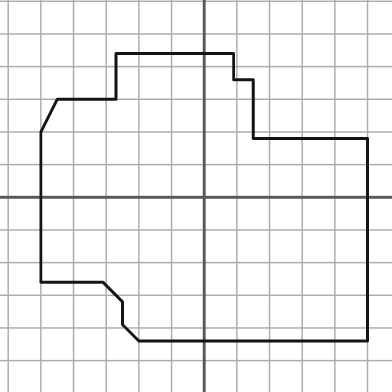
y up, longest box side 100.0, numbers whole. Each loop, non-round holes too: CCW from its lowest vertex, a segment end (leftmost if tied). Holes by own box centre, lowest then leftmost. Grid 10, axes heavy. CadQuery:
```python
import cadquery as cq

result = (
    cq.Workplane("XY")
    .moveTo(-20.0, -44.0)
    .lineTo(50.0, -44.0)
    .lineTo(50.0, 18.0)
    .lineTo(15.0, 18.0)
    .lineTo(15.0, 36.0)
    .lineTo(9.0, 36.0)
    .lineTo(9.0, 44.0)
    .lineTo(-27.0, 44.0)
    .lineTo(-27.0, 30.0)
    .lineTo(-45.0, 30.0)
    .lineTo(-50.0, 20.0)
    .lineTo(-50.0, -26.0)
    .lineTo(-31.0, -26.0)
    .lineTo(-25.0, -32.0)
    .lineTo(-25.0, -39.0)
    .close()
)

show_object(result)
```